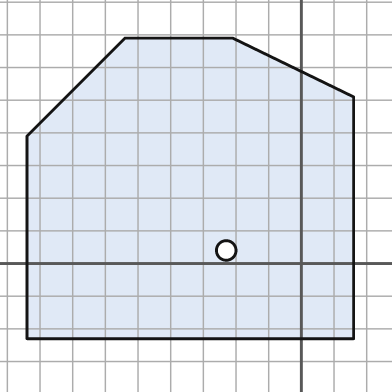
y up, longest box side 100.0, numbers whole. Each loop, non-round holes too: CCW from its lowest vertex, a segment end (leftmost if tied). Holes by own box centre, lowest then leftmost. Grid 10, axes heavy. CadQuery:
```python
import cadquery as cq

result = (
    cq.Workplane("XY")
    .moveTo(-84.0, -23.0)
    .lineTo(16.0, -23.0)
    .lineTo(16.0, 51.0)
    .lineTo(-21.0, 69.0)
    .lineTo(-54.0, 69.0)
    .lineTo(-84.0, 39.0)
    .close()
    .moveTo(-23.0, 4.0)
    .circle(3.0)
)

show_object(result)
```